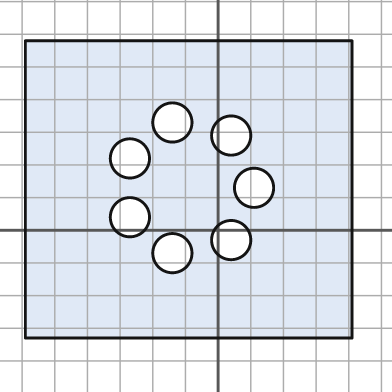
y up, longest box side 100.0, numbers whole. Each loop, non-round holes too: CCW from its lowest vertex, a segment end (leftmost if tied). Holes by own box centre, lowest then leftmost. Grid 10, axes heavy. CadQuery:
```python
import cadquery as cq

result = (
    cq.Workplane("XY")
    .moveTo(-59.0, -33.0)
    .lineTo(41.0, -33.0)
    .lineTo(41.0, 58.0)
    .lineTo(-59.0, 58.0)
    .close()
    .moveTo(-14.0, -7.0)
    .circle(6.0)
    .moveTo(4.0, -3.0)
    .circle(6.0)
    .moveTo(-27.0, 4.0)
    .circle(6.0)
    .moveTo(11.0, 13.0)
    .circle(6.0)
    .moveTo(-27.0, 22.0)
    .circle(6.0)
    .moveTo(4.0, 29.0)
    .circle(6.0)
    .moveTo(-14.0, 33.0)
    .circle(6.0)
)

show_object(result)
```